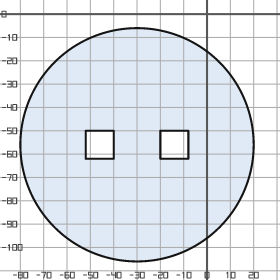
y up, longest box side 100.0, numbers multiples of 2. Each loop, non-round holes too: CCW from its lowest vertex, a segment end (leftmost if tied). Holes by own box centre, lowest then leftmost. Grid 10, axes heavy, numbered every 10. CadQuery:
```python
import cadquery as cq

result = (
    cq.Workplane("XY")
    .moveTo(-30.0, -56.0)
    .circle(50.0)
    .moveTo(-52.0, -62.0)
    .lineTo(-40.0, -62.0)
    .lineTo(-40.0, -50.0)
    .lineTo(-52.0, -50.0)
    .close()
    .moveTo(-20.0, -62.0)
    .lineTo(-8.0, -62.0)
    .lineTo(-8.0, -50.0)
    .lineTo(-20.0, -50.0)
    .close()
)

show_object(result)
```